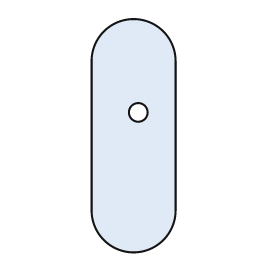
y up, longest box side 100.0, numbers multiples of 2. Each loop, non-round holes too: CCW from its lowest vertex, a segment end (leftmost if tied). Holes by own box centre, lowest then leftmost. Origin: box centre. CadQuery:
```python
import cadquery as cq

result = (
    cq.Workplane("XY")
    .moveTo(-18.0, -32.0)
    .threePointArc((0.0, -50.0), (18.0, -32.0))
    .lineTo(18.0, 32.0)
    .threePointArc((0.0, 50.0), (-18.0, 32.0))
    .close()
    .moveTo(2.0, 10.0)
    .circle(4.0)
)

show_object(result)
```